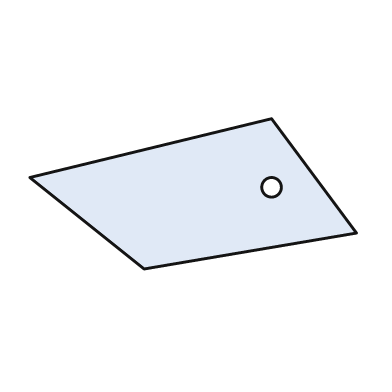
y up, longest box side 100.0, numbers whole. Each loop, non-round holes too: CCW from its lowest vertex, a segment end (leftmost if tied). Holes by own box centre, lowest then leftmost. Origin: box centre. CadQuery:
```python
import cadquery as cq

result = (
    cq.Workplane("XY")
    .moveTo(-15.0, -23.0)
    .lineTo(50.0, -12.0)
    .lineTo(24.0, 23.0)
    .lineTo(-50.0, 5.0)
    .close()
    .moveTo(24.0, 2.0)
    .circle(3.0)
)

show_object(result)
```